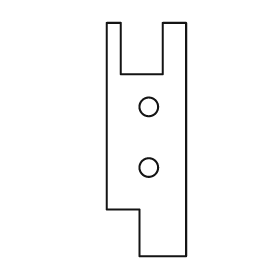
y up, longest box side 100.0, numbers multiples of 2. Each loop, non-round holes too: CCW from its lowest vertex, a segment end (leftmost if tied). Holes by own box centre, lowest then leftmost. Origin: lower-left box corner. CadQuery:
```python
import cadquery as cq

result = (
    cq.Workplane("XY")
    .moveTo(14.0, 0.0)
    .lineTo(34.0, 0.0)
    .lineTo(34.0, 100.0)
    .lineTo(24.0, 100.0)
    .lineTo(24.0, 78.0)
    .lineTo(6.0, 78.0)
    .lineTo(6.0, 100.0)
    .lineTo(0.0, 100.0)
    .lineTo(0.0, 20.0)
    .lineTo(14.0, 20.0)
    .close()
    .moveTo(18.0, 38.0)
    .circle(4.0)
    .moveTo(18.0, 64.0)
    .circle(4.0)
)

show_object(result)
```